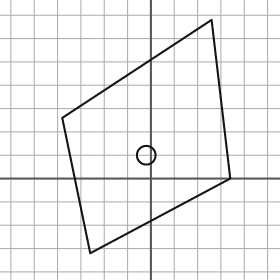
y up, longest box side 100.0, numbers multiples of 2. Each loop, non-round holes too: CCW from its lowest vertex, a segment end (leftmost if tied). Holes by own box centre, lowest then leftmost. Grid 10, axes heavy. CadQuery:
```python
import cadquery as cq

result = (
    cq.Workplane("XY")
    .moveTo(-26.0, -32.0)
    .lineTo(34.0, 0.0)
    .lineTo(26.0, 68.0)
    .lineTo(-38.0, 26.0)
    .close()
    .moveTo(-2.0, 10.0)
    .circle(4.0)
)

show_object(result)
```